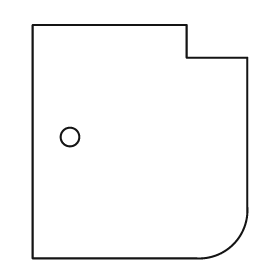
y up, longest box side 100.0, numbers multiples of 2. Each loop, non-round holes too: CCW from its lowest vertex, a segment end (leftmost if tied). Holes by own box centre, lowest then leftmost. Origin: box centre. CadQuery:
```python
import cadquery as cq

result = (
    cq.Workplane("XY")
    .moveTo(-46.0, -50.0)
    .lineTo(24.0, -50.0)
    .threePointArc((40.0, -44.0), (46.0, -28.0))
    .lineTo(46.0, 36.0)
    .lineTo(20.0, 36.0)
    .lineTo(20.0, 50.0)
    .lineTo(-46.0, 50.0)
    .close()
    .moveTo(-30.0, 2.0)
    .circle(4.0)
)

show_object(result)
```